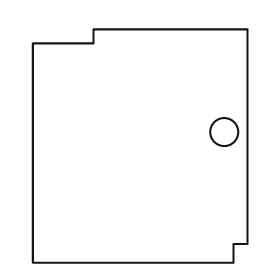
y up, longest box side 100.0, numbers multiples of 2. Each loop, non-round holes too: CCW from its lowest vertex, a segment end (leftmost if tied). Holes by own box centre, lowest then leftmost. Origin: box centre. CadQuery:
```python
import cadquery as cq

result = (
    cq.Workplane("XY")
    .moveTo(-46.0, -50.0)
    .lineTo(40.0, -50.0)
    .lineTo(40.0, -42.0)
    .lineTo(46.0, -42.0)
    .lineTo(46.0, 50.0)
    .lineTo(-20.0, 50.0)
    .lineTo(-20.0, 44.0)
    .lineTo(-46.0, 44.0)
    .close()
    .moveTo(36.0, 6.0)
    .circle(6.0)
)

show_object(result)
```